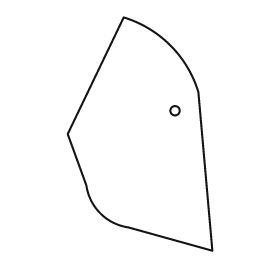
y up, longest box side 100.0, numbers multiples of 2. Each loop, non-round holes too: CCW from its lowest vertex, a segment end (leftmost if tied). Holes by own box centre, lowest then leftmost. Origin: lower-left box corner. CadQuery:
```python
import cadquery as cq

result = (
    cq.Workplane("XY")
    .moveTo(62.0, 0.0)
    .lineTo(56.0, 68.0)
    .threePointArc((44.0, 88.0), (24.0, 100.0))
    .lineTo(0.0, 50.0)
    .lineTo(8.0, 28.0)
    .threePointArc((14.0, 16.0), (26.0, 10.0))
    .close()
    .moveTo(46.0, 60.0)
    .circle(2.0)
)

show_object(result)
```